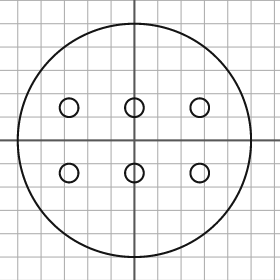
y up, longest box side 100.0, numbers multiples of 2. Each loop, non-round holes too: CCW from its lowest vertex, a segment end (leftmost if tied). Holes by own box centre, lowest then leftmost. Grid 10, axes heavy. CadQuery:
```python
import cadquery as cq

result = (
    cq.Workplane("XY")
    .moveTo(0.0, 0.0)
    .circle(50.0)
    .moveTo(-28.0, -14.0)
    .circle(4.0)
    .moveTo(0.0, -14.0)
    .circle(4.0)
    .moveTo(28.0, -14.0)
    .circle(4.0)
    .moveTo(-28.0, 14.0)
    .circle(4.0)
    .moveTo(0.0, 14.0)
    .circle(4.0)
    .moveTo(28.0, 14.0)
    .circle(4.0)
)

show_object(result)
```